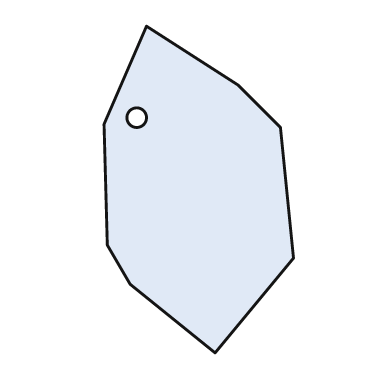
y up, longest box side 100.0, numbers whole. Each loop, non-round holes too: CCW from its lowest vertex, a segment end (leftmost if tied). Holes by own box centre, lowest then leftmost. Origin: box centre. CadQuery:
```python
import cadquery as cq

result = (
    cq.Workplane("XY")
    .moveTo(5.0, -50.0)
    .lineTo(29.0, -21.0)
    .lineTo(25.0, 19.0)
    .lineTo(12.0, 32.0)
    .lineTo(-16.0, 50.0)
    .lineTo(-29.0, 20.0)
    .lineTo(-28.0, -17.0)
    .lineTo(-21.0, -29.0)
    .close()
    .moveTo(-19.0, 22.0)
    .circle(3.0)
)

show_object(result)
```